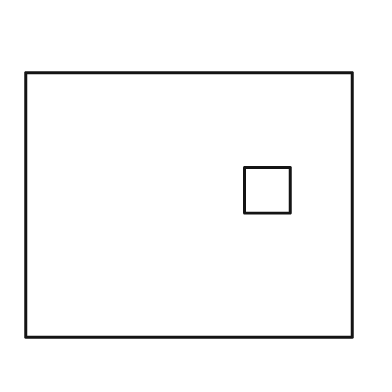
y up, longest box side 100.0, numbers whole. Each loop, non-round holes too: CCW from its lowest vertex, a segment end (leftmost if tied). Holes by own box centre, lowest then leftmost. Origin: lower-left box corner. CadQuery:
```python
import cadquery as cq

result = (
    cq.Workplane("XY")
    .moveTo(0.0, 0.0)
    .lineTo(100.0, 0.0)
    .lineTo(100.0, 81.0)
    .lineTo(0.0, 81.0)
    .close()
    .moveTo(67.0, 38.0)
    .lineTo(81.0, 38.0)
    .lineTo(81.0, 52.0)
    .lineTo(67.0, 52.0)
    .close()
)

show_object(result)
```